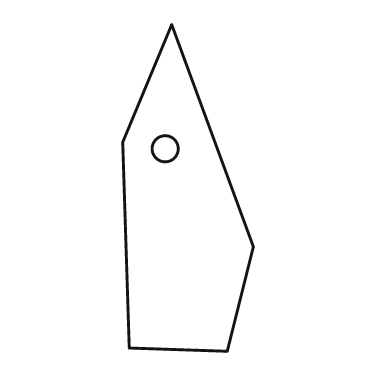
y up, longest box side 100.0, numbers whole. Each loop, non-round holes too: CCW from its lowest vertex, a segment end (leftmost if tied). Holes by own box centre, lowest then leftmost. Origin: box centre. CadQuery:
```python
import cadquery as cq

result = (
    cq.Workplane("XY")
    .moveTo(12.0, -50.0)
    .lineTo(20.0, -18.0)
    .lineTo(-5.0, 50.0)
    .lineTo(-20.0, 14.0)
    .lineTo(-18.0, -49.0)
    .close()
    .moveTo(-7.0, 12.0)
    .circle(4.0)
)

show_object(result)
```